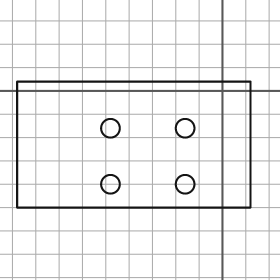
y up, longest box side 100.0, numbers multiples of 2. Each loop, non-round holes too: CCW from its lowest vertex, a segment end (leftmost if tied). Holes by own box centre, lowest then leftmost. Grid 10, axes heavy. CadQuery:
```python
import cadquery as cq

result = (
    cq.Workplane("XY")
    .moveTo(-88.0, -50.0)
    .lineTo(12.0, -50.0)
    .lineTo(12.0, 4.0)
    .lineTo(-88.0, 4.0)
    .close()
    .moveTo(-48.0, -40.0)
    .circle(4.0)
    .moveTo(-16.0, -40.0)
    .circle(4.0)
    .moveTo(-48.0, -16.0)
    .circle(4.0)
    .moveTo(-16.0, -16.0)
    .circle(4.0)
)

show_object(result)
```